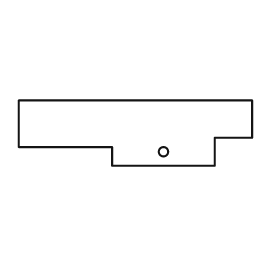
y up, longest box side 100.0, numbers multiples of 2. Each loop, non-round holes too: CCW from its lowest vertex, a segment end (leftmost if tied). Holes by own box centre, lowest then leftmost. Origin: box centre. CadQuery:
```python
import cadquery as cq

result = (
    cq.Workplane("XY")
    .moveTo(-10.0, -14.0)
    .lineTo(34.0, -14.0)
    .lineTo(34.0, -2.0)
    .lineTo(50.0, -2.0)
    .lineTo(50.0, 14.0)
    .lineTo(-50.0, 14.0)
    .lineTo(-50.0, -6.0)
    .lineTo(-10.0, -6.0)
    .close()
    .moveTo(12.0, -8.0)
    .circle(2.0)
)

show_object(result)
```